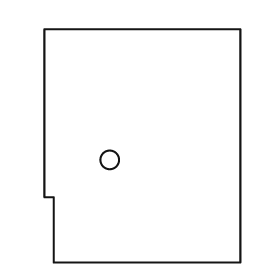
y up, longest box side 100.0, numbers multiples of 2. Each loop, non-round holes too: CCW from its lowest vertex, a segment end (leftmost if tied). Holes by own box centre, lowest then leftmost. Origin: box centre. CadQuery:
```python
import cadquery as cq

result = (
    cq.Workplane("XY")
    .moveTo(-38.0, -50.0)
    .lineTo(42.0, -50.0)
    .lineTo(42.0, 50.0)
    .lineTo(-42.0, 50.0)
    .lineTo(-42.0, -22.0)
    .lineTo(-38.0, -22.0)
    .close()
    .moveTo(-14.0, -6.0)
    .circle(4.0)
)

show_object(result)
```